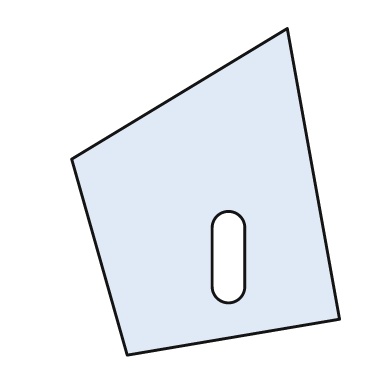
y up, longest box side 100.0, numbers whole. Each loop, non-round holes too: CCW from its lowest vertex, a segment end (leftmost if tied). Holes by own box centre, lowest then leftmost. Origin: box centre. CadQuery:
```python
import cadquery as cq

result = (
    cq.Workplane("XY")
    .moveTo(-24.0, -50.0)
    .lineTo(41.0, -39.0)
    .lineTo(25.0, 50.0)
    .lineTo(-41.0, 10.0)
    .close()
    .moveTo(2.0, -29.0)
    .threePointArc((7.0, -34.0), (12.0, -29.0))
    .lineTo(12.0, -11.0)
    .threePointArc((7.0, -6.0), (2.0, -11.0))
    .close()
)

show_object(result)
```